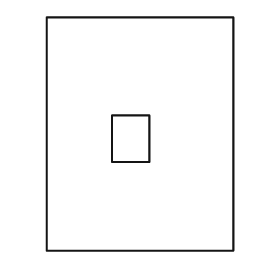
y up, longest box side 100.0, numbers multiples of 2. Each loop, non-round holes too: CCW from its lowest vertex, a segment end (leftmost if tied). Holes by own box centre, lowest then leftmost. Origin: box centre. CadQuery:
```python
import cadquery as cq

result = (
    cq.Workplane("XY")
    .moveTo(-40.0, -50.0)
    .lineTo(40.0, -50.0)
    .lineTo(40.0, 50.0)
    .lineTo(-40.0, 50.0)
    .close()
    .moveTo(-12.0, -12.0)
    .lineTo(4.0, -12.0)
    .lineTo(4.0, 8.0)
    .lineTo(-12.0, 8.0)
    .close()
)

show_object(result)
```